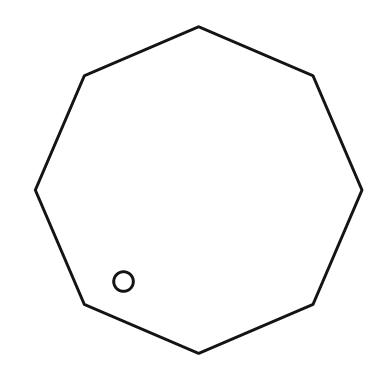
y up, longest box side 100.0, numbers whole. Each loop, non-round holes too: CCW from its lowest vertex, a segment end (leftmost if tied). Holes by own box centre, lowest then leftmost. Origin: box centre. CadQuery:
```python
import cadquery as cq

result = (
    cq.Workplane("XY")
    .moveTo(0.0, -50.0)
    .lineTo(35.0, -35.0)
    .lineTo(50.0, 0.0)
    .lineTo(35.0, 35.0)
    .lineTo(0.0, 50.0)
    .lineTo(-35.0, 35.0)
    .lineTo(-50.0, 0.0)
    .lineTo(-35.0, -35.0)
    .close()
    .moveTo(-23.0, -28.0)
    .circle(3.0)
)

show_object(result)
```